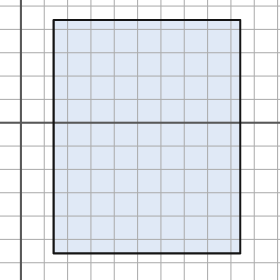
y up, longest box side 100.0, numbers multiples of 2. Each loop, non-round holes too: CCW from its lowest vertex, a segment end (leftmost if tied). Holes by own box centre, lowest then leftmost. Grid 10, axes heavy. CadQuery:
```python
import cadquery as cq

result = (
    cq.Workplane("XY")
    .moveTo(14.0, -56.0)
    .lineTo(94.0, -56.0)
    .lineTo(94.0, 44.0)
    .lineTo(14.0, 44.0)
    .close()
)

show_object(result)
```